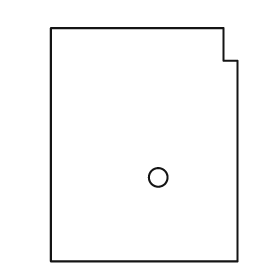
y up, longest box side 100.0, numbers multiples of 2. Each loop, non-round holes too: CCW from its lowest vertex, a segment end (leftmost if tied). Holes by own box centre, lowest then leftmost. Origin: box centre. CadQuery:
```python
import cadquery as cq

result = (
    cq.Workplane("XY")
    .moveTo(-40.0, -50.0)
    .lineTo(40.0, -50.0)
    .lineTo(40.0, 36.0)
    .lineTo(34.0, 36.0)
    .lineTo(34.0, 50.0)
    .lineTo(-40.0, 50.0)
    .close()
    .moveTo(6.0, -14.0)
    .circle(4.0)
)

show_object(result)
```